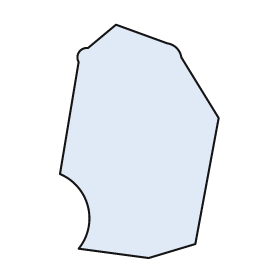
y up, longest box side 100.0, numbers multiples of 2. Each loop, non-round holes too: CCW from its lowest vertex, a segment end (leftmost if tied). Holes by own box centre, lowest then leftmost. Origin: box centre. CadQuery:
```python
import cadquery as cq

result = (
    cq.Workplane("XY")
    .moveTo(4.0, -50.0)
    .lineTo(24.0, -44.0)
    .lineTo(34.0, 10.0)
    .lineTo(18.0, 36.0)
    .threePointArc((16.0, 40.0), (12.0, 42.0))
    .lineTo(-10.0, 50.0)
    .lineTo(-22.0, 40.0)
    .threePointArc((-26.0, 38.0), (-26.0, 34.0))
    .lineTo(-34.0, -14.0)
    .threePointArc((-22.0, -28.0), (-26.0, -46.0))
    .close()
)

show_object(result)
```